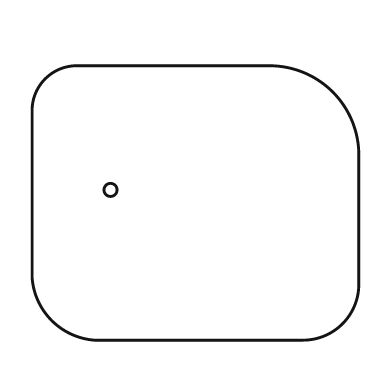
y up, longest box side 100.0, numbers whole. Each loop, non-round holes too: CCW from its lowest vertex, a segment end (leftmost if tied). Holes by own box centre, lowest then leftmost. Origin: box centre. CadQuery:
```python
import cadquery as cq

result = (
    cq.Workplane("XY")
    .moveTo(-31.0, -42.0)
    .lineTo(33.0, -42.0)
    .threePointArc((45.0, -37.0), (50.0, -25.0))
    .lineTo(50.0, 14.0)
    .threePointArc((42.0, 34.0), (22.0, 42.0))
    .lineTo(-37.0, 42.0)
    .threePointArc((-46.0, 38.0), (-50.0, 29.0))
    .lineTo(-50.0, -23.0)
    .threePointArc((-44.0, -36.0), (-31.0, -42.0))
    .close()
    .moveTo(-26.0, 4.0)
    .circle(2.0)
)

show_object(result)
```